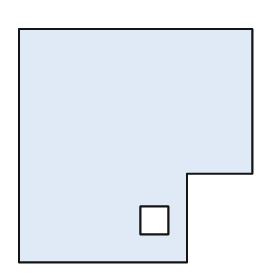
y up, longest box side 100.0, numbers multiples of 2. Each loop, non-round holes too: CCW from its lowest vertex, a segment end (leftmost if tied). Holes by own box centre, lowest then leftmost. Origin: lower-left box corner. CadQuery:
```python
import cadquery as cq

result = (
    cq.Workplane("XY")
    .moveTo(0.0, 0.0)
    .lineTo(72.0, 0.0)
    .lineTo(72.0, 38.0)
    .lineTo(100.0, 38.0)
    .lineTo(100.0, 100.0)
    .lineTo(0.0, 100.0)
    .close()
    .moveTo(52.0, 12.0)
    .lineTo(64.0, 12.0)
    .lineTo(64.0, 24.0)
    .lineTo(52.0, 24.0)
    .close()
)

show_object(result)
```